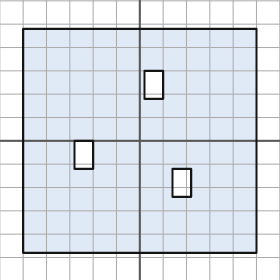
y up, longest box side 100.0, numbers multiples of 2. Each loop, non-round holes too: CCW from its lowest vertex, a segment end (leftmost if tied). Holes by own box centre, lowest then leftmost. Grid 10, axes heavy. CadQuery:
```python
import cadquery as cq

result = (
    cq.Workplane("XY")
    .moveTo(-50.0, -48.0)
    .lineTo(50.0, -48.0)
    .lineTo(50.0, 48.0)
    .lineTo(-50.0, 48.0)
    .close()
    .moveTo(14.0, -24.0)
    .lineTo(22.0, -24.0)
    .lineTo(22.0, -12.0)
    .lineTo(14.0, -12.0)
    .close()
    .moveTo(-28.0, -12.0)
    .lineTo(-20.0, -12.0)
    .lineTo(-20.0, 0.0)
    .lineTo(-28.0, 0.0)
    .close()
    .moveTo(2.0, 18.0)
    .lineTo(10.0, 18.0)
    .lineTo(10.0, 30.0)
    .lineTo(2.0, 30.0)
    .close()
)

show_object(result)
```